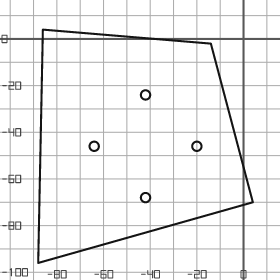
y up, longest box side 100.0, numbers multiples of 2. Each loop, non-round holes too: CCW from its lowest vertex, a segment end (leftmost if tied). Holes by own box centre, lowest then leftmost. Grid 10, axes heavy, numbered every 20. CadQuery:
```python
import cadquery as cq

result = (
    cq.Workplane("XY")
    .moveTo(-88.0, -96.0)
    .lineTo(4.0, -70.0)
    .lineTo(-14.0, -2.0)
    .lineTo(-86.0, 4.0)
    .close()
    .moveTo(-42.0, -68.0)
    .circle(2.0)
    .moveTo(-64.0, -46.0)
    .circle(2.0)
    .moveTo(-20.0, -46.0)
    .circle(2.0)
    .moveTo(-42.0, -24.0)
    .circle(2.0)
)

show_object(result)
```